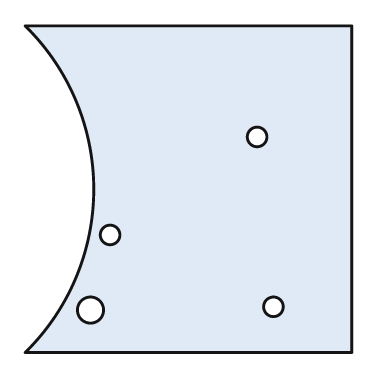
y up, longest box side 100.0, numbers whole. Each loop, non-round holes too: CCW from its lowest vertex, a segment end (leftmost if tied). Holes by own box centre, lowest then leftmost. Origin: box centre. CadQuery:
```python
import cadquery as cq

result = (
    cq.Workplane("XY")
    .moveTo(-50.0, -50.0)
    .lineTo(50.0, -50.0)
    .lineTo(50.0, 50.0)
    .lineTo(-50.0, 50.0)
    .threePointArc((-29.0, 0.0), (-50.0, -50.0))
    .close()
    .moveTo(-30.0, -37.0)
    .circle(4.0)
    .moveTo(26.0, -36.0)
    .circle(3.0)
    .moveTo(-24.0, -14.0)
    .circle(3.0)
    .moveTo(21.0, 16.0)
    .circle(3.0)
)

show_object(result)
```